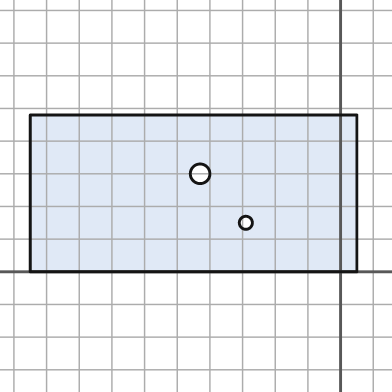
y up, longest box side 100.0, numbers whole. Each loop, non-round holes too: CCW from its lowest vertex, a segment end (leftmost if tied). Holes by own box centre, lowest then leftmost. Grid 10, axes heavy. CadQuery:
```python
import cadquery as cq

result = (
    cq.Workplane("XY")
    .moveTo(-95.0, 0.0)
    .lineTo(5.0, 0.0)
    .lineTo(5.0, 48.0)
    .lineTo(-95.0, 48.0)
    .close()
    .moveTo(-29.0, 15.0)
    .circle(2.0)
    .moveTo(-43.0, 30.0)
    .circle(3.0)
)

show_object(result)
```